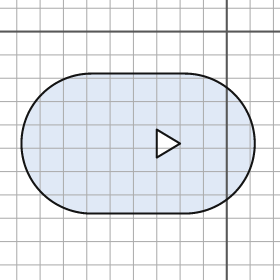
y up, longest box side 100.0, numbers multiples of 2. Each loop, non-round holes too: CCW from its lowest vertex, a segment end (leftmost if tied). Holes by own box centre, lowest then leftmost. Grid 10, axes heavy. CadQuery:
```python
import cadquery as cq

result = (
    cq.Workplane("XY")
    .moveTo(-58.0, -78.0)
    .lineTo(-18.0, -78.0)
    .threePointArc((12.0, -48.0), (-18.0, -18.0))
    .lineTo(-58.0, -18.0)
    .threePointArc((-88.0, -48.0), (-58.0, -78.0))
    .close()
    .moveTo(-30.0, -54.0)
    .lineTo(-20.0, -48.0)
    .lineTo(-30.0, -42.0)
    .close()
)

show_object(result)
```